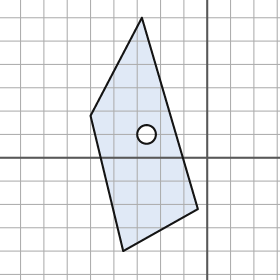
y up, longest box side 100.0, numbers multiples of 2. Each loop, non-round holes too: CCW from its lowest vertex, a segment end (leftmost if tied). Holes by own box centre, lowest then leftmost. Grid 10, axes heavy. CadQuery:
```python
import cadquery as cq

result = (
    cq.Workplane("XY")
    .moveTo(-36.0, -40.0)
    .lineTo(-4.0, -22.0)
    .lineTo(-28.0, 60.0)
    .lineTo(-50.0, 18.0)
    .close()
    .moveTo(-26.0, 10.0)
    .circle(4.0)
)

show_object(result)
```